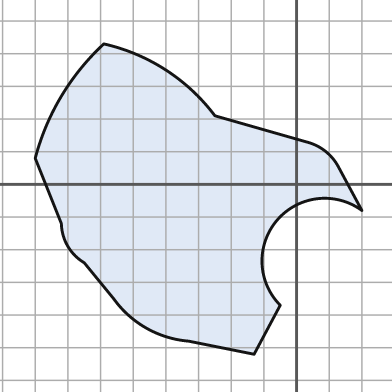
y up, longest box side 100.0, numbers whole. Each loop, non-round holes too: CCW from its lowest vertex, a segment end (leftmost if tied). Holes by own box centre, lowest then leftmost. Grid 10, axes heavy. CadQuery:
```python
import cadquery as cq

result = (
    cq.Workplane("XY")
    .moveTo(-13.0, -52.0)
    .lineTo(-5.0, -37.0)
    .threePointArc((-6.0, -11.0), (20.0, -8.0))
    .lineTo(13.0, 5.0)
    .threePointArc((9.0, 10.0), (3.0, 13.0))
    .lineTo(-25.0, 21.0)
    .threePointArc((-40.0, 35.0), (-59.0, 43.0))
    .threePointArc((-72.0, 27.0), (-80.0, 8.0))
    .lineTo(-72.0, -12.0)
    .threePointArc((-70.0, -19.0), (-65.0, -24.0))
    .lineTo(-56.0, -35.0)
    .threePointArc((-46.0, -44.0), (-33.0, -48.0))
    .close()
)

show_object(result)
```